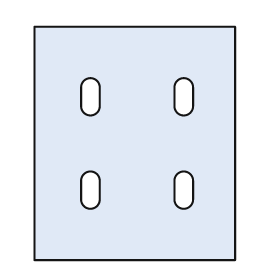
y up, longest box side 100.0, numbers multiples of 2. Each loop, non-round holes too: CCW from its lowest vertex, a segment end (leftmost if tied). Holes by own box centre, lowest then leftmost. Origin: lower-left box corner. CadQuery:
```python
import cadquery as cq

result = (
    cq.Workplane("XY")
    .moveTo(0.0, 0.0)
    .lineTo(86.0, 0.0)
    .lineTo(86.0, 100.0)
    .lineTo(0.0, 100.0)
    .close()
    .moveTo(20.0, 26.0)
    .threePointArc((24.0, 22.0), (28.0, 26.0))
    .lineTo(28.0, 34.0)
    .threePointArc((24.0, 38.0), (20.0, 34.0))
    .close()
    .moveTo(60.0, 26.0)
    .threePointArc((64.0, 22.0), (68.0, 26.0))
    .lineTo(68.0, 34.0)
    .threePointArc((64.0, 38.0), (60.0, 34.0))
    .close()
    .moveTo(20.0, 66.0)
    .threePointArc((24.0, 62.0), (28.0, 66.0))
    .lineTo(28.0, 74.0)
    .threePointArc((24.0, 78.0), (20.0, 74.0))
    .close()
    .moveTo(60.0, 66.0)
    .threePointArc((64.0, 62.0), (68.0, 66.0))
    .lineTo(68.0, 74.0)
    .threePointArc((64.0, 78.0), (60.0, 74.0))
    .close()
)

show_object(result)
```